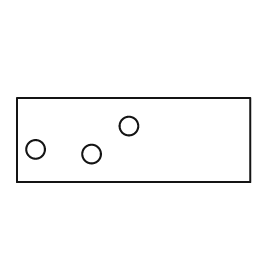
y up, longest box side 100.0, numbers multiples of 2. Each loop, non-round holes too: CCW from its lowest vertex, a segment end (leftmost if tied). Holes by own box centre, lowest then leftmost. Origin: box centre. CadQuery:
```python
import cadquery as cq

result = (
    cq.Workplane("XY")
    .moveTo(-50.0, -18.0)
    .lineTo(50.0, -18.0)
    .lineTo(50.0, 18.0)
    .lineTo(-50.0, 18.0)
    .close()
    .moveTo(-18.0, -6.0)
    .circle(4.0)
    .moveTo(-42.0, -4.0)
    .circle(4.0)
    .moveTo(-2.0, 6.0)
    .circle(4.0)
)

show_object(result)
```